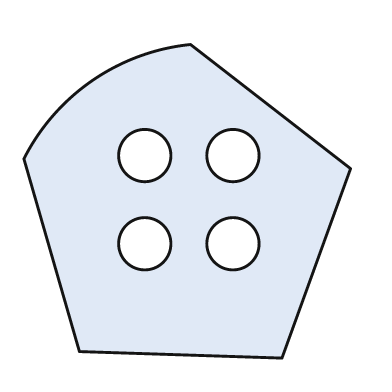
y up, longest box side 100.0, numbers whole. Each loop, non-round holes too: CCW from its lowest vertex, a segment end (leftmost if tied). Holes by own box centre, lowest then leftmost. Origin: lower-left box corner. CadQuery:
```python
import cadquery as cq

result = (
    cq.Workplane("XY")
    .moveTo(79.0, 0.0)
    .lineTo(100.0, 58.0)
    .lineTo(51.0, 96.0)
    .threePointArc((21.0, 85.0), (0.0, 61.0))
    .lineTo(17.0, 2.0)
    .close()
    .moveTo(37.0, 35.0)
    .circle(8.0)
    .moveTo(64.0, 35.0)
    .circle(8.0)
    .moveTo(37.0, 62.0)
    .circle(8.0)
    .moveTo(64.0, 62.0)
    .circle(8.0)
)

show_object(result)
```